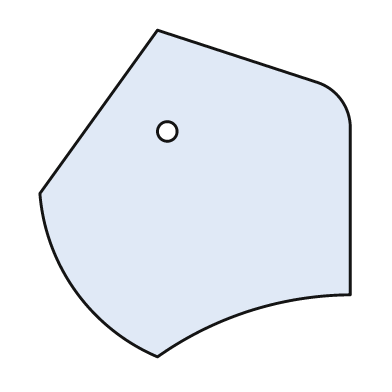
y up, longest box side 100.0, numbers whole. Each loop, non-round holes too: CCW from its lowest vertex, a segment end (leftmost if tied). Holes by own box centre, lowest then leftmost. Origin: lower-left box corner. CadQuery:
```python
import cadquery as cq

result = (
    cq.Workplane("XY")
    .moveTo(36.0, 0.0)
    .threePointArc((64.0, 14.0), (95.0, 19.0))
    .lineTo(95.0, 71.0)
    .threePointArc((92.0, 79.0), (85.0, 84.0))
    .lineTo(36.0, 100.0)
    .lineTo(0.0, 50.0)
    .threePointArc((11.0, 20.0), (36.0, 0.0))
    .close()
    .moveTo(39.0, 69.0)
    .circle(3.0)
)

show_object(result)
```